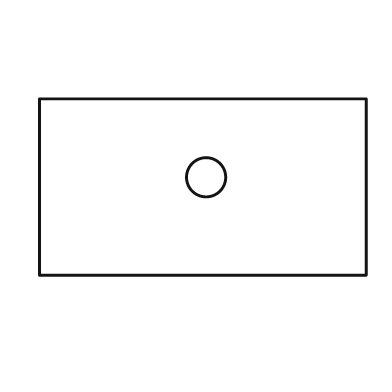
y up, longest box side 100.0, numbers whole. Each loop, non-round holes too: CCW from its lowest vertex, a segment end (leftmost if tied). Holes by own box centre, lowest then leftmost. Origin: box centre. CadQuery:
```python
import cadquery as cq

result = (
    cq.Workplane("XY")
    .moveTo(-50.0, -27.0)
    .lineTo(50.0, -27.0)
    .lineTo(50.0, 27.0)
    .lineTo(-50.0, 27.0)
    .close()
    .moveTo(1.0, 3.0)
    .circle(6.0)
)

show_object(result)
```